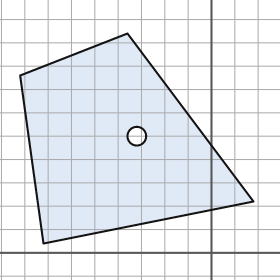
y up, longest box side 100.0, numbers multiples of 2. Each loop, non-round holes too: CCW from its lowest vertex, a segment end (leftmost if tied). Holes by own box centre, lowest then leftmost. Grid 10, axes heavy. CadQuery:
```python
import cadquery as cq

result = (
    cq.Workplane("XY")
    .moveTo(-72.0, 4.0)
    .lineTo(18.0, 22.0)
    .lineTo(-36.0, 94.0)
    .lineTo(-82.0, 76.0)
    .close()
    .moveTo(-32.0, 50.0)
    .circle(4.0)
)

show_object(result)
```